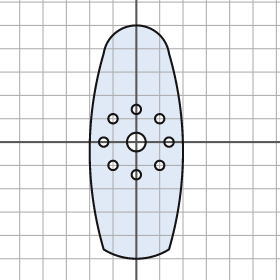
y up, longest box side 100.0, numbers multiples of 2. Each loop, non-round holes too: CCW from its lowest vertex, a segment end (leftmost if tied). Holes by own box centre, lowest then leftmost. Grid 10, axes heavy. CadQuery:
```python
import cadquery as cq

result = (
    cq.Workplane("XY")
    .moveTo(-14.0, -46.0)
    .threePointArc((0.0, -50.0), (14.0, -46.0))
    .threePointArc((20.0, -4.0), (14.0, 38.0))
    .threePointArc((0.0, 50.0), (-14.0, 38.0))
    .threePointArc((-20.0, -4.0), (-14.0, -46.0))
    .close()
    .moveTo(0.0, -14.0)
    .circle(2.0)
    .moveTo(-10.0, -10.0)
    .circle(2.0)
    .moveTo(10.0, -10.0)
    .circle(2.0)
    .moveTo(-14.0, 0.0)
    .circle(2.0)
    .moveTo(0.0, 0.0)
    .circle(4.0)
    .moveTo(14.0, 0.0)
    .circle(2.0)
    .moveTo(-10.0, 10.0)
    .circle(2.0)
    .moveTo(10.0, 10.0)
    .circle(2.0)
    .moveTo(0.0, 14.0)
    .circle(2.0)
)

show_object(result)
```